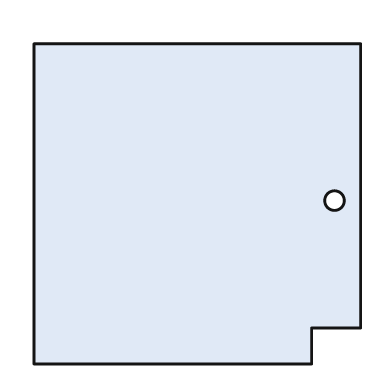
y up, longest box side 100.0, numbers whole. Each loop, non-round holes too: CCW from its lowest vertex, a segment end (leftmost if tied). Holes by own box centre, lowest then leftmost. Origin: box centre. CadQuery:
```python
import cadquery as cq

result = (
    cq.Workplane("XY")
    .moveTo(-50.0, -49.0)
    .lineTo(35.0, -49.0)
    .lineTo(35.0, -38.0)
    .lineTo(50.0, -38.0)
    .lineTo(50.0, 49.0)
    .lineTo(-50.0, 49.0)
    .close()
    .moveTo(42.0, 1.0)
    .circle(3.0)
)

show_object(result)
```